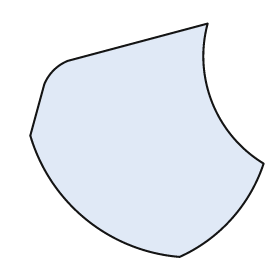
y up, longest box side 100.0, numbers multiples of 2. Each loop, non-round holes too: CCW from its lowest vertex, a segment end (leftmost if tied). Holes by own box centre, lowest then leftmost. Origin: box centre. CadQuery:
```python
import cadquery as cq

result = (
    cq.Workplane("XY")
    .moveTo(14.0, -50.0)
    .threePointArc((36.0, -34.0), (50.0, -10.0))
    .threePointArc((28.0, 16.0), (26.0, 50.0))
    .lineTo(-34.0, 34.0)
    .threePointArc((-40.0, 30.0), (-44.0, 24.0))
    .lineTo(-50.0, 2.0)
    .threePointArc((-26.0, -34.0), (14.0, -50.0))
    .close()
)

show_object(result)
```